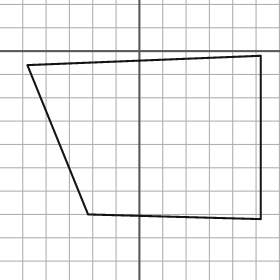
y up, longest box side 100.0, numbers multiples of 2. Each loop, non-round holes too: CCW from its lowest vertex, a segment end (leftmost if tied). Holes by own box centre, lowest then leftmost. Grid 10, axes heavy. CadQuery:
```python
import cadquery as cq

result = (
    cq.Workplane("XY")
    .moveTo(52.0, -72.0)
    .lineTo(52.0, -2.0)
    .lineTo(-48.0, -6.0)
    .lineTo(-22.0, -70.0)
    .close()
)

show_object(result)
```